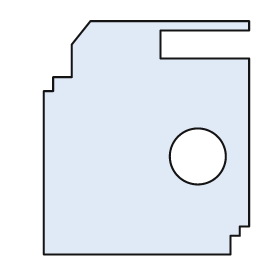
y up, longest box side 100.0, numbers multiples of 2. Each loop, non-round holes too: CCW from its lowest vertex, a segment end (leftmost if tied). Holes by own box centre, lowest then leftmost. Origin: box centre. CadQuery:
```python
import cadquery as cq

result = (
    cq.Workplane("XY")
    .moveTo(-44.0, -50.0)
    .lineTo(36.0, -50.0)
    .lineTo(36.0, -42.0)
    .lineTo(40.0, -42.0)
    .lineTo(40.0, -38.0)
    .lineTo(44.0, -38.0)
    .lineTo(44.0, 34.0)
    .lineTo(6.0, 34.0)
    .lineTo(6.0, 46.0)
    .lineTo(44.0, 46.0)
    .lineTo(44.0, 50.0)
    .lineTo(-24.0, 50.0)
    .lineTo(-32.0, 40.0)
    .lineTo(-32.0, 26.0)
    .lineTo(-40.0, 26.0)
    .lineTo(-40.0, 20.0)
    .lineTo(-44.0, 20.0)
    .close()
    .moveTo(22.0, -8.0)
    .circle(12.0)
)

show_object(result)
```